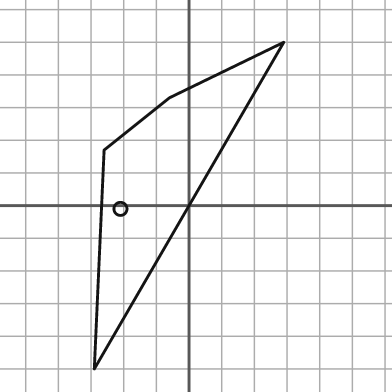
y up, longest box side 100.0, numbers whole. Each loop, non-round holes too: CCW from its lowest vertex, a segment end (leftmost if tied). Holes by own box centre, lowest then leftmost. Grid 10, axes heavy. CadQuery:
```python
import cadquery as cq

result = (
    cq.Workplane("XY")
    .moveTo(-29.0, -50.0)
    .lineTo(29.0, 50.0)
    .lineTo(-6.0, 33.0)
    .lineTo(-26.0, 17.0)
    .close()
    .moveTo(-21.0, -1.0)
    .circle(2.0)
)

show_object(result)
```